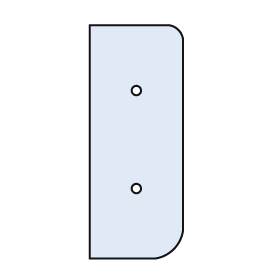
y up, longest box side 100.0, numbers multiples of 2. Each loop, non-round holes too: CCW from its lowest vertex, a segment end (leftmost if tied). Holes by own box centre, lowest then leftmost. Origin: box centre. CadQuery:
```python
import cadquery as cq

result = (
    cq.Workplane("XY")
    .moveTo(-20.0, -50.0)
    .lineTo(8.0, -50.0)
    .threePointArc((16.0, -46.0), (20.0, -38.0))
    .lineTo(20.0, 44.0)
    .threePointArc((18.0, 48.0), (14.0, 50.0))
    .lineTo(-20.0, 50.0)
    .close()
    .moveTo(0.0, -20.0)
    .circle(2.0)
    .moveTo(0.0, 22.0)
    .circle(2.0)
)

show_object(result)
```